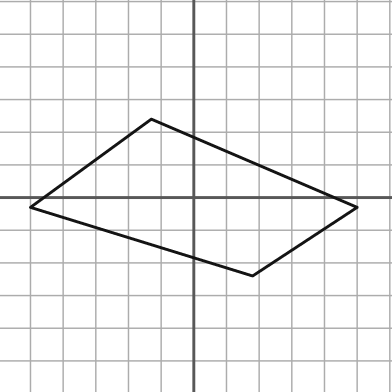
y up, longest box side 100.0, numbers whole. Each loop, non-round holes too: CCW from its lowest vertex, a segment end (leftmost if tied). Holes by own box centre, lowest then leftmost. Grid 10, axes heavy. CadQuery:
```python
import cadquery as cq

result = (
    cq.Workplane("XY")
    .moveTo(18.0, -24.0)
    .lineTo(50.0, -3.0)
    .lineTo(-13.0, 24.0)
    .lineTo(-50.0, -3.0)
    .close()
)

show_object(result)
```